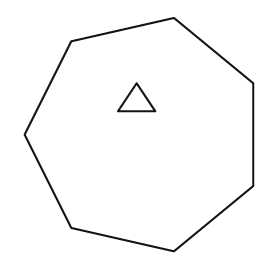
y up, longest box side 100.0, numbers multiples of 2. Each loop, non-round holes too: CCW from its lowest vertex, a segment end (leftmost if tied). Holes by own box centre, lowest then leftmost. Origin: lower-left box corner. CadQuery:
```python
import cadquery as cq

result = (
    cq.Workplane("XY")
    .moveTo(64.0, 0.0)
    .lineTo(98.0, 28.0)
    .lineTo(98.0, 72.0)
    .lineTo(64.0, 100.0)
    .lineTo(20.0, 90.0)
    .lineTo(0.0, 50.0)
    .lineTo(20.0, 10.0)
    .close()
    .moveTo(40.0, 60.0)
    .lineTo(56.0, 60.0)
    .lineTo(48.0, 72.0)
    .close()
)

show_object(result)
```